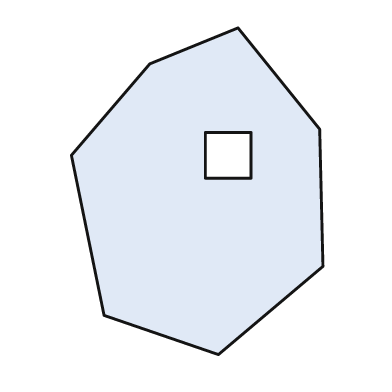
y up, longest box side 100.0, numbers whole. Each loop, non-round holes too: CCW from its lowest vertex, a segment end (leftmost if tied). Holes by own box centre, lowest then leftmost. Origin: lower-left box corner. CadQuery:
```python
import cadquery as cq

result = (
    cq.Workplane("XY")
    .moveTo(45.0, 0.0)
    .lineTo(77.0, 27.0)
    .lineTo(76.0, 69.0)
    .lineTo(51.0, 100.0)
    .lineTo(24.0, 89.0)
    .lineTo(0.0, 61.0)
    .lineTo(10.0, 12.0)
    .close()
    .moveTo(41.0, 54.0)
    .lineTo(55.0, 54.0)
    .lineTo(55.0, 68.0)
    .lineTo(41.0, 68.0)
    .close()
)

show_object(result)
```